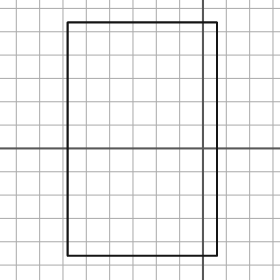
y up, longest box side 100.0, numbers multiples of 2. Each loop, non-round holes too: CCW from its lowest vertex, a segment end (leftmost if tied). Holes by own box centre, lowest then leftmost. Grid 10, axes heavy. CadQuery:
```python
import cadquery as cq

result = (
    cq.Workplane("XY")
    .moveTo(-58.0, -46.0)
    .lineTo(6.0, -46.0)
    .lineTo(6.0, 54.0)
    .lineTo(-58.0, 54.0)
    .close()
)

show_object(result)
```